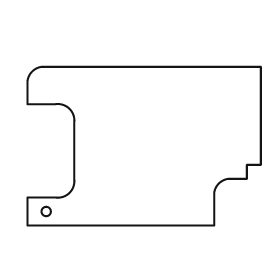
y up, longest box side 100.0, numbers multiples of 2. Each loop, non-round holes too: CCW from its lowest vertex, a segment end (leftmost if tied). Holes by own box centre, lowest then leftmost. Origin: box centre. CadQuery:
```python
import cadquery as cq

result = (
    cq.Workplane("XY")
    .moveTo(-50.0, -34.0)
    .lineTo(30.0, -34.0)
    .lineTo(30.0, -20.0)
    .threePointArc((32.0, -16.0), (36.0, -14.0))
    .lineTo(44.0, -14.0)
    .lineTo(44.0, -8.0)
    .lineTo(50.0, -8.0)
    .lineTo(50.0, 34.0)
    .lineTo(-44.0, 34.0)
    .threePointArc((-48.0, 32.0), (-50.0, 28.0))
    .lineTo(-50.0, 18.0)
    .lineTo(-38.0, 18.0)
    .threePointArc((-32.0, 16.0), (-30.0, 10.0))
    .lineTo(-30.0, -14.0)
    .threePointArc((-32.0, -20.0), (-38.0, -22.0))
    .lineTo(-50.0, -22.0)
    .close()
    .moveTo(-42.0, -28.0)
    .circle(2.0)
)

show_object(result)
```